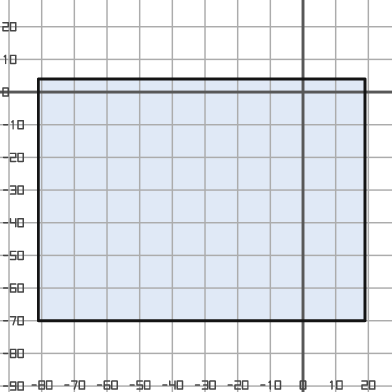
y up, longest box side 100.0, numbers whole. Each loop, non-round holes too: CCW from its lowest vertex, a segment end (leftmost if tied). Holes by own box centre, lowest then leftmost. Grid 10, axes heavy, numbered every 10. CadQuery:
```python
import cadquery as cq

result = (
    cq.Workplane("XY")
    .moveTo(-81.0, -70.0)
    .lineTo(19.0, -70.0)
    .lineTo(19.0, 4.0)
    .lineTo(-81.0, 4.0)
    .close()
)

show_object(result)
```